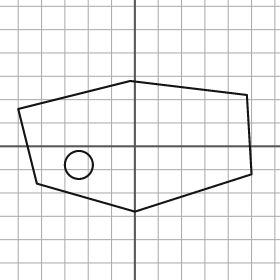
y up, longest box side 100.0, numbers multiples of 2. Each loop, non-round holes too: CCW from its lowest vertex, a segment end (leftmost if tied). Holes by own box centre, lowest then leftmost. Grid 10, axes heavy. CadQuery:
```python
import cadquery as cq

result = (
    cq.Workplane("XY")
    .moveTo(0.0, -28.0)
    .lineTo(50.0, -12.0)
    .lineTo(48.0, 22.0)
    .lineTo(-2.0, 28.0)
    .lineTo(-50.0, 16.0)
    .lineTo(-42.0, -16.0)
    .close()
    .moveTo(-24.0, -8.0)
    .circle(6.0)
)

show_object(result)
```